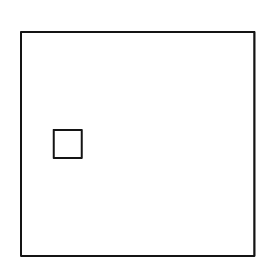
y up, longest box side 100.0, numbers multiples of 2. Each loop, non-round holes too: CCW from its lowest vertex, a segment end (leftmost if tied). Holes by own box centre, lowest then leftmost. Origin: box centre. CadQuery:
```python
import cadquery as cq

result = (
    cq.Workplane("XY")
    .moveTo(-50.0, -48.0)
    .lineTo(50.0, -48.0)
    .lineTo(50.0, 48.0)
    .lineTo(-50.0, 48.0)
    .close()
    .moveTo(-36.0, -6.0)
    .lineTo(-24.0, -6.0)
    .lineTo(-24.0, 6.0)
    .lineTo(-36.0, 6.0)
    .close()
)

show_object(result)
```